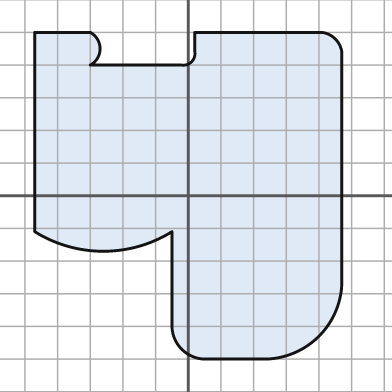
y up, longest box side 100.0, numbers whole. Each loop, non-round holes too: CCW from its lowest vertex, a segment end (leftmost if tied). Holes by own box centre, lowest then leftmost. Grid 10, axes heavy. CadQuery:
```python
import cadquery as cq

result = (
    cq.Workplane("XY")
    .moveTo(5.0, -50.0)
    .lineTo(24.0, -50.0)
    .threePointArc((40.0, -43.0), (47.0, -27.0))
    .lineTo(47.0, 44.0)
    .threePointArc((45.0, 48.0), (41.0, 50.0))
    .lineTo(2.0, 50.0)
    .lineTo(2.0, 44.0)
    .threePointArc((1.0, 41.0), (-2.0, 40.0))
    .lineTo(-30.0, 40.0)
    .threePointArc((-27.0, 45.0), (-30.0, 50.0))
    .lineTo(-47.0, 50.0)
    .lineTo(-47.0, -11.0)
    .threePointArc((-26.0, -17.0), (-5.0, -11.0))
    .lineTo(-5.0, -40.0)
    .threePointArc((-2.0, -47.0), (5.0, -50.0))
    .close()
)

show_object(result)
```